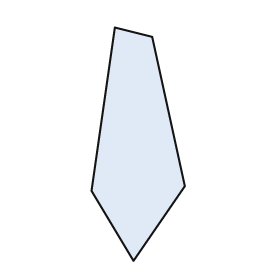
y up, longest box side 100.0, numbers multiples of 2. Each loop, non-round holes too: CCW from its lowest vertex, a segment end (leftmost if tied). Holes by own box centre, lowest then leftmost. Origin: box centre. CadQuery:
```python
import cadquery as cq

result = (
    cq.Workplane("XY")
    .moveTo(-2.0, -50.0)
    .lineTo(20.0, -18.0)
    .lineTo(6.0, 46.0)
    .lineTo(-10.0, 50.0)
    .lineTo(-20.0, -20.0)
    .close()
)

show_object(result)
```